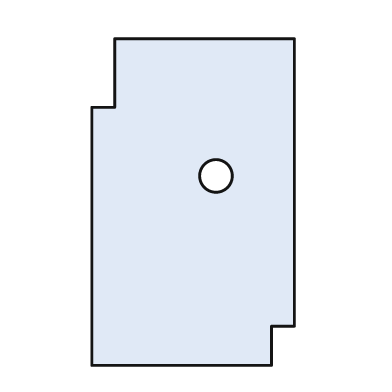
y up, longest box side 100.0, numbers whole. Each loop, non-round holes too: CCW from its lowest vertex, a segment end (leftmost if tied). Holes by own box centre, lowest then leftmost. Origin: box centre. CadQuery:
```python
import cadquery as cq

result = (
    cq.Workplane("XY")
    .moveTo(-31.0, -50.0)
    .lineTo(24.0, -50.0)
    .lineTo(24.0, -38.0)
    .lineTo(31.0, -38.0)
    .lineTo(31.0, 50.0)
    .lineTo(-24.0, 50.0)
    .lineTo(-24.0, 29.0)
    .lineTo(-31.0, 29.0)
    .close()
    .moveTo(7.0, 8.0)
    .circle(5.0)
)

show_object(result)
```